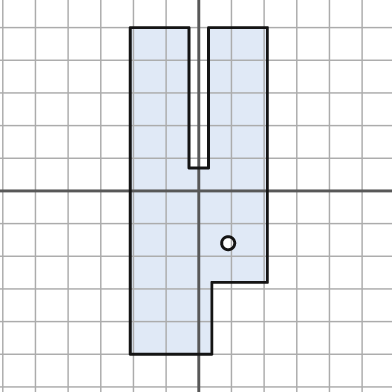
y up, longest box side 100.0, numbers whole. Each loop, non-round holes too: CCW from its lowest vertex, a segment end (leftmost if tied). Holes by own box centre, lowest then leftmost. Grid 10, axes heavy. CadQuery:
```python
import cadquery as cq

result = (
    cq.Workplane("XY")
    .moveTo(-21.0, -50.0)
    .lineTo(4.0, -50.0)
    .lineTo(4.0, -28.0)
    .lineTo(21.0, -28.0)
    .lineTo(21.0, 50.0)
    .lineTo(3.0, 50.0)
    .lineTo(3.0, 7.0)
    .lineTo(-3.0, 7.0)
    .lineTo(-3.0, 50.0)
    .lineTo(-21.0, 50.0)
    .close()
    .moveTo(9.0, -16.0)
    .circle(2.0)
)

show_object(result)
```